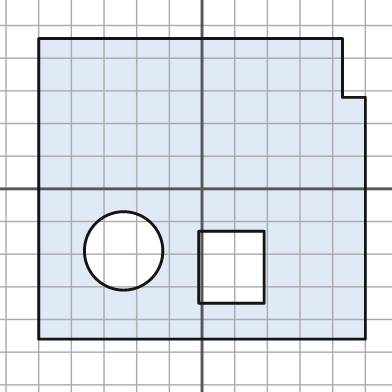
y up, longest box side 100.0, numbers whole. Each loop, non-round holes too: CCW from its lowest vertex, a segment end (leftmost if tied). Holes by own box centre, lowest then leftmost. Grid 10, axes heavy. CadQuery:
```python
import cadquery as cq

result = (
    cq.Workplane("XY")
    .moveTo(-50.0, -46.0)
    .lineTo(50.0, -46.0)
    .lineTo(50.0, 28.0)
    .lineTo(43.0, 28.0)
    .lineTo(43.0, 46.0)
    .lineTo(-50.0, 46.0)
    .close()
    .moveTo(-1.0, -35.0)
    .lineTo(19.0, -35.0)
    .lineTo(19.0, -13.0)
    .lineTo(-1.0, -13.0)
    .close()
    .moveTo(-24.0, -19.0)
    .circle(12.0)
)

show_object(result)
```